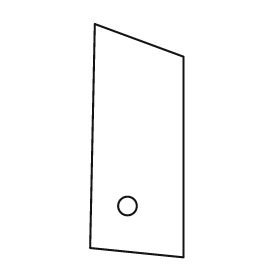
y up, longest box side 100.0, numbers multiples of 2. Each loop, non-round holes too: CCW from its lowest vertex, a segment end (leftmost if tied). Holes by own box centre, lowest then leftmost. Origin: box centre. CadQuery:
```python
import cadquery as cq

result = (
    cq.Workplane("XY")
    .moveTo(20.0, -50.0)
    .lineTo(20.0, 36.0)
    .lineTo(-18.0, 50.0)
    .lineTo(-20.0, -46.0)
    .close()
    .moveTo(-4.0, -28.0)
    .circle(4.0)
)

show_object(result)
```